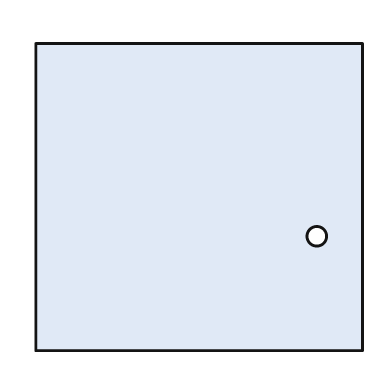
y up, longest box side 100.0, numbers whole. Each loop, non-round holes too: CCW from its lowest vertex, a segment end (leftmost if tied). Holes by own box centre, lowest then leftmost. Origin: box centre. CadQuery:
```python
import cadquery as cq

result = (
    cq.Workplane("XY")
    .moveTo(-50.0, -47.0)
    .lineTo(50.0, -47.0)
    .lineTo(50.0, 47.0)
    .lineTo(-50.0, 47.0)
    .close()
    .moveTo(36.0, -12.0)
    .circle(3.0)
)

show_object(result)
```